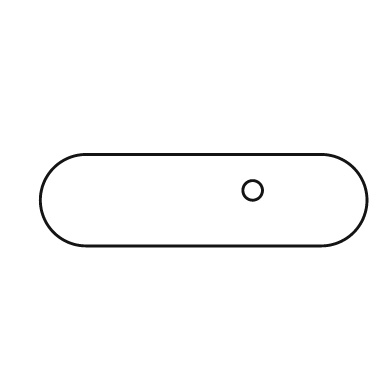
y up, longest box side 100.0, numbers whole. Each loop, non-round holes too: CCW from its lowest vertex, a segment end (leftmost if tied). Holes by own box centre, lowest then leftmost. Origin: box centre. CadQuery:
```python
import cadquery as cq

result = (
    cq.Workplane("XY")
    .moveTo(-36.0, -14.0)
    .lineTo(36.0, -14.0)
    .threePointArc((50.0, 0.0), (36.0, 14.0))
    .lineTo(-36.0, 14.0)
    .threePointArc((-50.0, 0.0), (-36.0, -14.0))
    .close()
    .moveTo(15.0, 3.0)
    .circle(3.0)
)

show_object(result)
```